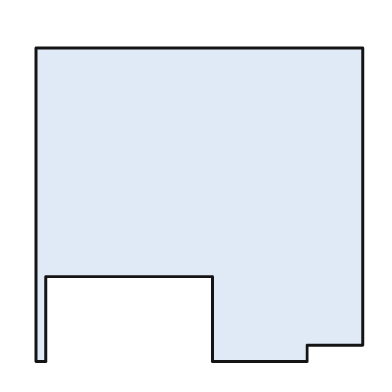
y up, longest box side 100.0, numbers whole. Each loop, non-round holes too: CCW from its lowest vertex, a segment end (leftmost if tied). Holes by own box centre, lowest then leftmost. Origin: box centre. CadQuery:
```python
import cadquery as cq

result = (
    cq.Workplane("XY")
    .moveTo(-50.0, -48.0)
    .lineTo(-47.0, -48.0)
    .lineTo(-47.0, -22.0)
    .lineTo(4.0, -22.0)
    .lineTo(4.0, -48.0)
    .lineTo(33.0, -48.0)
    .lineTo(33.0, -43.0)
    .lineTo(50.0, -43.0)
    .lineTo(50.0, 48.0)
    .lineTo(-50.0, 48.0)
    .close()
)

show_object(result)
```